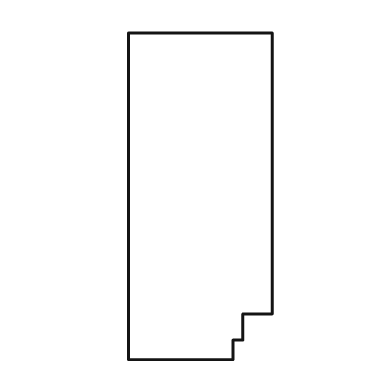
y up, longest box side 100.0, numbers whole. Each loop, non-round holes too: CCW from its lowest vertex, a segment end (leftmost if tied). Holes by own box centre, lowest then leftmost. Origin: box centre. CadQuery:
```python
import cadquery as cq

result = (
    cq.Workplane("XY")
    .moveTo(-22.0, -50.0)
    .lineTo(10.0, -50.0)
    .lineTo(10.0, -44.0)
    .lineTo(13.0, -44.0)
    .lineTo(13.0, -36.0)
    .lineTo(22.0, -36.0)
    .lineTo(22.0, 50.0)
    .lineTo(-22.0, 50.0)
    .close()
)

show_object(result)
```